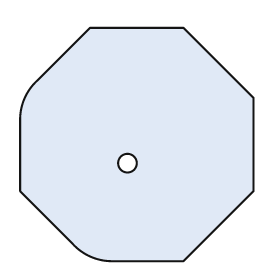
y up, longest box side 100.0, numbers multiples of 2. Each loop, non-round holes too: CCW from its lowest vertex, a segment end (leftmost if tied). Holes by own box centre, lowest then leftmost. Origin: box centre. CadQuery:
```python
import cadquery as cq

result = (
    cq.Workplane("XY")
    .moveTo(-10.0, -50.0)
    .lineTo(20.0, -50.0)
    .lineTo(50.0, -20.0)
    .lineTo(50.0, 20.0)
    .lineTo(20.0, 50.0)
    .lineTo(-20.0, 50.0)
    .lineTo(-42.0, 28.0)
    .threePointArc((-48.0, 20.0), (-50.0, 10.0))
    .lineTo(-50.0, -20.0)
    .lineTo(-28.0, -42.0)
    .threePointArc((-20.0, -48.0), (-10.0, -50.0))
    .close()
    .moveTo(-4.0, -8.0)
    .circle(4.0)
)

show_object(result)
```